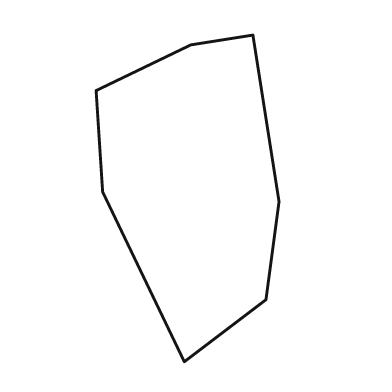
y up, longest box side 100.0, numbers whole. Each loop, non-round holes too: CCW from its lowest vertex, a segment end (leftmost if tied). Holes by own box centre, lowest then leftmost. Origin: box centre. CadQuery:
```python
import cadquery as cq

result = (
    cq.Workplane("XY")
    .moveTo(-1.0, -50.0)
    .lineTo(24.0, -31.0)
    .lineTo(28.0, -1.0)
    .lineTo(20.0, 50.0)
    .lineTo(1.0, 47.0)
    .lineTo(-28.0, 33.0)
    .lineTo(-26.0, 2.0)
    .close()
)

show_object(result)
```